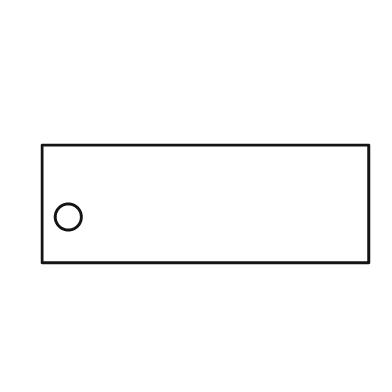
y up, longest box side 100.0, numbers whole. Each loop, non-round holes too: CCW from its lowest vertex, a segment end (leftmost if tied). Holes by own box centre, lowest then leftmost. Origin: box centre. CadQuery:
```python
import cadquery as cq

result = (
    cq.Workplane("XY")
    .moveTo(-50.0, -18.0)
    .lineTo(50.0, -18.0)
    .lineTo(50.0, 18.0)
    .lineTo(-50.0, 18.0)
    .close()
    .moveTo(-42.0, -4.0)
    .circle(4.0)
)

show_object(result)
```